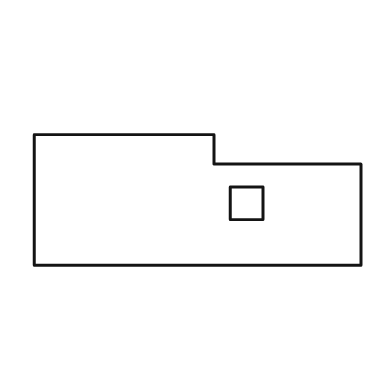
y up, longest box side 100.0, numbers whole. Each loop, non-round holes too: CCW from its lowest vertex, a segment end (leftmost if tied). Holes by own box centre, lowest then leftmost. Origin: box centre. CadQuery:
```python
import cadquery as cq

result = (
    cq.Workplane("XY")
    .moveTo(-50.0, -20.0)
    .lineTo(50.0, -20.0)
    .lineTo(50.0, 11.0)
    .lineTo(5.0, 11.0)
    .lineTo(5.0, 20.0)
    .lineTo(-50.0, 20.0)
    .close()
    .moveTo(10.0, -6.0)
    .lineTo(20.0, -6.0)
    .lineTo(20.0, 4.0)
    .lineTo(10.0, 4.0)
    .close()
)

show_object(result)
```